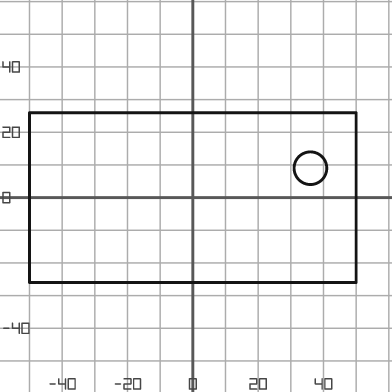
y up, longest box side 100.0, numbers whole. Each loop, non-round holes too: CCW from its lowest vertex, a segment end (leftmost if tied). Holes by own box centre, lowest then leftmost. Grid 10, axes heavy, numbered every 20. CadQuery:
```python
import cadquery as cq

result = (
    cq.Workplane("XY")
    .moveTo(-50.0, -26.0)
    .lineTo(50.0, -26.0)
    .lineTo(50.0, 26.0)
    .lineTo(-50.0, 26.0)
    .close()
    .moveTo(36.0, 9.0)
    .circle(5.0)
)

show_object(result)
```